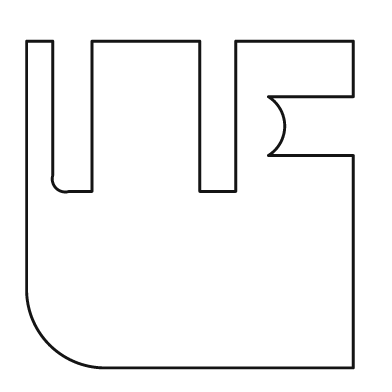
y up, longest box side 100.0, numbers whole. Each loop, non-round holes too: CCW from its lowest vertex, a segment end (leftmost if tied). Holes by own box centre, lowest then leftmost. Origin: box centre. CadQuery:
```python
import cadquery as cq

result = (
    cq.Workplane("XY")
    .moveTo(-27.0, -50.0)
    .lineTo(50.0, -50.0)
    .lineTo(50.0, 15.0)
    .lineTo(24.0, 15.0)
    .threePointArc((29.0, 24.0), (24.0, 33.0))
    .lineTo(50.0, 33.0)
    .lineTo(50.0, 50.0)
    .lineTo(14.0, 50.0)
    .lineTo(14.0, 4.0)
    .lineTo(3.0, 4.0)
    .lineTo(3.0, 50.0)
    .lineTo(-30.0, 50.0)
    .lineTo(-30.0, 4.0)
    .lineTo(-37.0, 4.0)
    .threePointArc((-41.0, 5.0), (-42.0, 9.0))
    .lineTo(-42.0, 50.0)
    .lineTo(-50.0, 50.0)
    .lineTo(-50.0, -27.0)
    .threePointArc((-43.0, -43.0), (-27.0, -50.0))
    .close()
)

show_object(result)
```